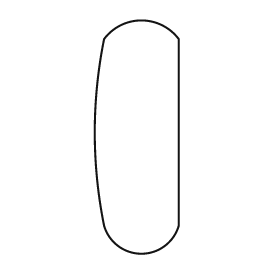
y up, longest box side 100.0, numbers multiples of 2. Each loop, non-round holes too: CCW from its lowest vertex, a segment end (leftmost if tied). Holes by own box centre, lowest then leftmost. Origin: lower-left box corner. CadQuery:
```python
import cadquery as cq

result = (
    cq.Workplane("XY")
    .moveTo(4.0, 12.0)
    .threePointArc((20.0, 0.0), (36.0, 12.0))
    .lineTo(36.0, 92.0)
    .threePointArc((20.0, 100.0), (4.0, 92.0))
    .threePointArc((0.0, 52.0), (4.0, 12.0))
    .close()
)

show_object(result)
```